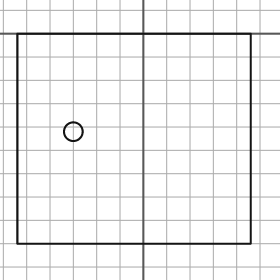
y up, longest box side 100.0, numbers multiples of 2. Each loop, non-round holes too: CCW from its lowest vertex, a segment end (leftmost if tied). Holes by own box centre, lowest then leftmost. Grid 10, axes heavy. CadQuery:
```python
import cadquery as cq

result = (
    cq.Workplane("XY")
    .moveTo(-54.0, -90.0)
    .lineTo(46.0, -90.0)
    .lineTo(46.0, 0.0)
    .lineTo(-54.0, 0.0)
    .close()
    .moveTo(-30.0, -42.0)
    .circle(4.0)
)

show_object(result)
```